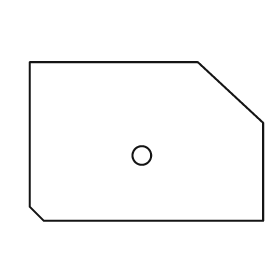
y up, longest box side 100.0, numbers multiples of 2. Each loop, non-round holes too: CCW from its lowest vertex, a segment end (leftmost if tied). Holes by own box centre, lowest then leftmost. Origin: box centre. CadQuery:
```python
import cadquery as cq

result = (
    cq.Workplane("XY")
    .moveTo(-44.0, -34.0)
    .lineTo(50.0, -34.0)
    .lineTo(50.0, 8.0)
    .lineTo(22.0, 34.0)
    .lineTo(-50.0, 34.0)
    .lineTo(-50.0, -28.0)
    .close()
    .moveTo(-2.0, -6.0)
    .circle(4.0)
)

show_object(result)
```